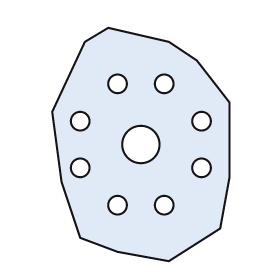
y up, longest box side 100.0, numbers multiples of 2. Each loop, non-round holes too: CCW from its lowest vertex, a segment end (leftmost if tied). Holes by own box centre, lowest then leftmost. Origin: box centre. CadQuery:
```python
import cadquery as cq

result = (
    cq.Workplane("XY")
    .moveTo(12.0, -50.0)
    .lineTo(34.0, -36.0)
    .lineTo(38.0, -14.0)
    .lineTo(38.0, 18.0)
    .lineTo(24.0, 36.0)
    .lineTo(12.0, 44.0)
    .lineTo(-14.0, 50.0)
    .lineTo(-24.0, 44.0)
    .lineTo(-38.0, 14.0)
    .lineTo(-34.0, -16.0)
    .lineTo(-26.0, -40.0)
    .lineTo(-10.0, -46.0)
    .close()
    .moveTo(-10.0, -26.0)
    .circle(4.0)
    .moveTo(10.0, -26.0)
    .circle(4.0)
    .moveTo(-26.0, -10.0)
    .circle(4.0)
    .moveTo(26.0, -10.0)
    .circle(4.0)
    .moveTo(0.0, 0.0)
    .circle(8.0)
    .moveTo(-26.0, 10.0)
    .circle(4.0)
    .moveTo(26.0, 10.0)
    .circle(4.0)
    .moveTo(-10.0, 26.0)
    .circle(4.0)
    .moveTo(10.0, 26.0)
    .circle(4.0)
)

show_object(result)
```